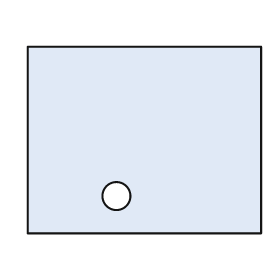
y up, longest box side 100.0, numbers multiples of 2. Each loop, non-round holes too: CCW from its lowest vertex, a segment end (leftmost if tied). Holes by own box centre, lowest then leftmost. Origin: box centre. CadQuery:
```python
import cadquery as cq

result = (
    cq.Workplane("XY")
    .moveTo(-50.0, -40.0)
    .lineTo(50.0, -40.0)
    .lineTo(50.0, 40.0)
    .lineTo(-50.0, 40.0)
    .close()
    .moveTo(-12.0, -24.0)
    .circle(6.0)
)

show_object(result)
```